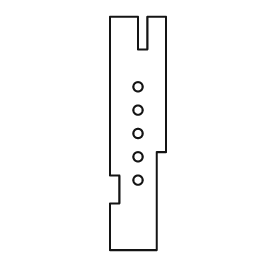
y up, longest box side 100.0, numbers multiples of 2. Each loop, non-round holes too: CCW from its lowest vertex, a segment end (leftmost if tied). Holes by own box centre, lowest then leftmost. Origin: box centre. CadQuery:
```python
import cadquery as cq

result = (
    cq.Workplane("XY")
    .moveTo(-12.0, -50.0)
    .lineTo(8.0, -50.0)
    .lineTo(8.0, -8.0)
    .lineTo(12.0, -8.0)
    .lineTo(12.0, 50.0)
    .lineTo(4.0, 50.0)
    .lineTo(4.0, 36.0)
    .lineTo(0.0, 36.0)
    .lineTo(0.0, 50.0)
    .lineTo(-12.0, 50.0)
    .lineTo(-12.0, -18.0)
    .lineTo(-8.0, -18.0)
    .lineTo(-8.0, -30.0)
    .lineTo(-12.0, -30.0)
    .close()
    .moveTo(0.0, -20.0)
    .circle(2.0)
    .moveTo(0.0, -10.0)
    .circle(2.0)
    .moveTo(0.0, 0.0)
    .circle(2.0)
    .moveTo(0.0, 10.0)
    .circle(2.0)
    .moveTo(0.0, 20.0)
    .circle(2.0)
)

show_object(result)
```